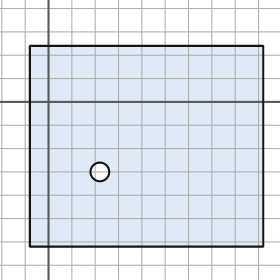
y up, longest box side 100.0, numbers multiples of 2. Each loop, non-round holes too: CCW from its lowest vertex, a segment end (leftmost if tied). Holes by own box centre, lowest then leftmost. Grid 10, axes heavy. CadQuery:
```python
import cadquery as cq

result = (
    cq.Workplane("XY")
    .moveTo(-8.0, -62.0)
    .lineTo(92.0, -62.0)
    .lineTo(92.0, 24.0)
    .lineTo(-8.0, 24.0)
    .close()
    .moveTo(22.0, -30.0)
    .circle(4.0)
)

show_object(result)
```